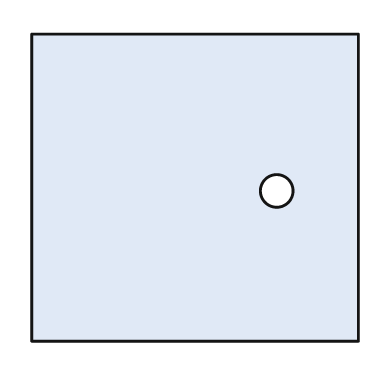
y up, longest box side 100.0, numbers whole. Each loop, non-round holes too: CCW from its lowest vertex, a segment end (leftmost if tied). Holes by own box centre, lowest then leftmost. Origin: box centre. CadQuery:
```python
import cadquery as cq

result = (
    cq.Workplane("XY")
    .moveTo(-50.0, -47.0)
    .lineTo(50.0, -47.0)
    .lineTo(50.0, 47.0)
    .lineTo(-50.0, 47.0)
    .close()
    .moveTo(25.0, -1.0)
    .circle(5.0)
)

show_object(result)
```